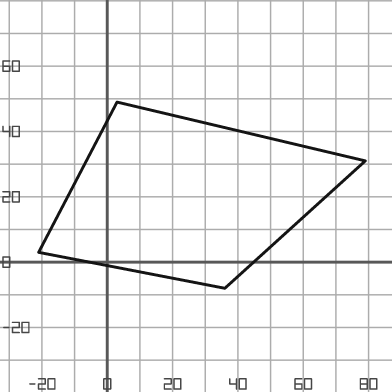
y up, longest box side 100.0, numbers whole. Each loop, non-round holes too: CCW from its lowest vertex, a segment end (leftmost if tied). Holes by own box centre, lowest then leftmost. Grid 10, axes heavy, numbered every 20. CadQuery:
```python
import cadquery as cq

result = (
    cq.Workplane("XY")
    .moveTo(36.0, -8.0)
    .lineTo(79.0, 31.0)
    .lineTo(3.0, 49.0)
    .lineTo(-21.0, 3.0)
    .close()
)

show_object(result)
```